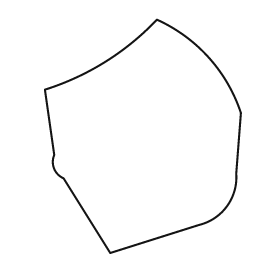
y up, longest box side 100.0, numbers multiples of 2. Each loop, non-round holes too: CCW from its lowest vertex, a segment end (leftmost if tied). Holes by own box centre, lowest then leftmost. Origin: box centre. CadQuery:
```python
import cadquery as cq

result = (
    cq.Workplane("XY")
    .moveTo(-14.0, -50.0)
    .lineTo(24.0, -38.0)
    .threePointArc((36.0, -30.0), (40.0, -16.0))
    .lineTo(42.0, 10.0)
    .threePointArc((28.0, 34.0), (6.0, 50.0))
    .threePointArc((-16.0, 32.0), (-42.0, 20.0))
    .lineTo(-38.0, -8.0)
    .threePointArc((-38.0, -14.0), (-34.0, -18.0))
    .close()
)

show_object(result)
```